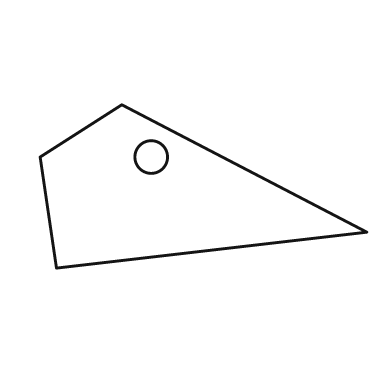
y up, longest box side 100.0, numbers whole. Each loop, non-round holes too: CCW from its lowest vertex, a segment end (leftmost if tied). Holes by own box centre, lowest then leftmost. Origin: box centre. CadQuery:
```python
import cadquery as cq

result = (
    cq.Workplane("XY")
    .moveTo(-45.0, -25.0)
    .lineTo(50.0, -14.0)
    .lineTo(-25.0, 25.0)
    .lineTo(-50.0, 9.0)
    .close()
    .moveTo(-16.0, 9.0)
    .circle(5.0)
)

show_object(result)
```